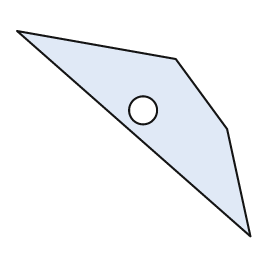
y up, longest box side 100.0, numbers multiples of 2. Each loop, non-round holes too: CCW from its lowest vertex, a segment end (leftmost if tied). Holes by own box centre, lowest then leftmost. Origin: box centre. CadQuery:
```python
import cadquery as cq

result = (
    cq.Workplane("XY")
    .moveTo(50.0, -44.0)
    .lineTo(40.0, 2.0)
    .lineTo(18.0, 32.0)
    .lineTo(-50.0, 44.0)
    .close()
    .moveTo(4.0, 10.0)
    .circle(6.0)
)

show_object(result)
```